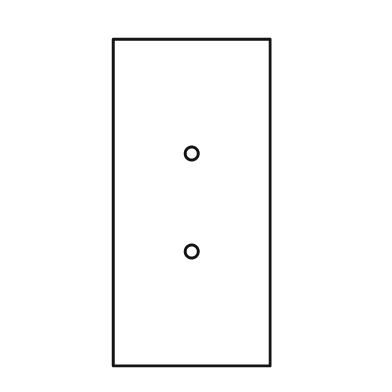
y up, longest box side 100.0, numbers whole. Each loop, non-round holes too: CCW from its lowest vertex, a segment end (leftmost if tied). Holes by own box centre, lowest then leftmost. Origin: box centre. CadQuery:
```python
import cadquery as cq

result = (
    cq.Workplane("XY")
    .moveTo(-24.0, -50.0)
    .lineTo(24.0, -50.0)
    .lineTo(24.0, 50.0)
    .lineTo(-24.0, 50.0)
    .close()
    .moveTo(0.0, -15.0)
    .circle(2.0)
    .moveTo(0.0, 15.0)
    .circle(2.0)
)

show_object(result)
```